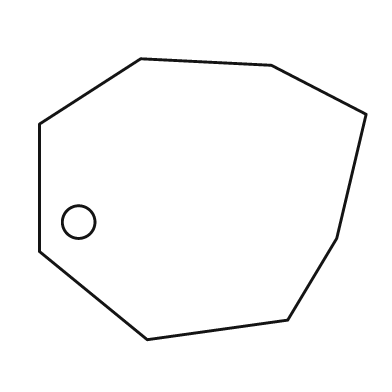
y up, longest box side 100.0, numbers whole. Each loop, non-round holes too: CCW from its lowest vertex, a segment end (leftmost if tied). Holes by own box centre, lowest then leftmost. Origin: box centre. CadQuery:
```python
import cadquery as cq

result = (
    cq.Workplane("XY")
    .moveTo(-17.0, -43.0)
    .lineTo(26.0, -37.0)
    .lineTo(41.0, -12.0)
    .lineTo(50.0, 26.0)
    .lineTo(21.0, 41.0)
    .lineTo(-19.0, 43.0)
    .lineTo(-50.0, 23.0)
    .lineTo(-50.0, -16.0)
    .close()
    .moveTo(-38.0, -7.0)
    .circle(5.0)
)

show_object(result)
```